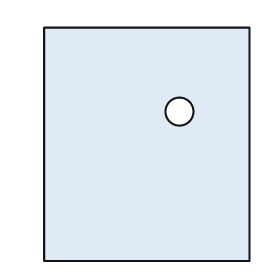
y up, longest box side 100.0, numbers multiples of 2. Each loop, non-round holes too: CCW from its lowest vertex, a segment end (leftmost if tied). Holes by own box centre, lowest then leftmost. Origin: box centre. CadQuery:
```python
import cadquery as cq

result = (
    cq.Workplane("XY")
    .moveTo(-44.0, -50.0)
    .lineTo(44.0, -50.0)
    .lineTo(44.0, 50.0)
    .lineTo(-44.0, 50.0)
    .close()
    .moveTo(14.0, 14.0)
    .circle(6.0)
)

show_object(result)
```